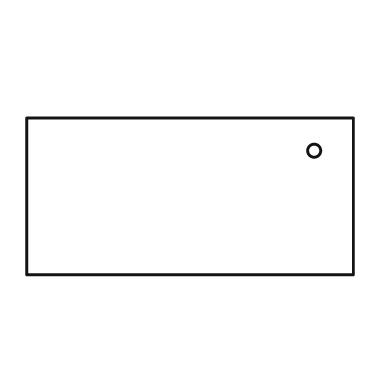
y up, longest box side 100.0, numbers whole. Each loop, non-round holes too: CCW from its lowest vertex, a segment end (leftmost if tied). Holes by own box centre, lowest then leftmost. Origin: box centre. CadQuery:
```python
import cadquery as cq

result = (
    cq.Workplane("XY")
    .moveTo(-50.0, -24.0)
    .lineTo(50.0, -24.0)
    .lineTo(50.0, 24.0)
    .lineTo(-50.0, 24.0)
    .close()
    .moveTo(38.0, 14.0)
    .circle(2.0)
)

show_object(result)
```